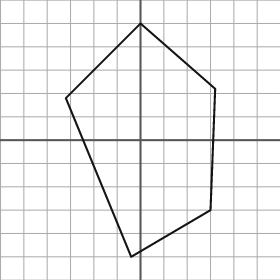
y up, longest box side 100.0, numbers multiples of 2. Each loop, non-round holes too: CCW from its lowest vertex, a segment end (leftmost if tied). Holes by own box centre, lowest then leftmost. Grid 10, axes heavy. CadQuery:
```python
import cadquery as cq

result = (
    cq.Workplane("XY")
    .moveTo(-4.0, -50.0)
    .lineTo(30.0, -30.0)
    .lineTo(32.0, 22.0)
    .lineTo(0.0, 50.0)
    .lineTo(-32.0, 18.0)
    .close()
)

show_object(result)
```